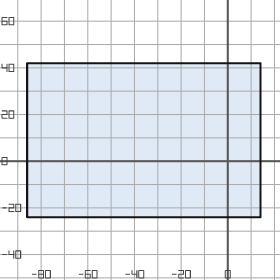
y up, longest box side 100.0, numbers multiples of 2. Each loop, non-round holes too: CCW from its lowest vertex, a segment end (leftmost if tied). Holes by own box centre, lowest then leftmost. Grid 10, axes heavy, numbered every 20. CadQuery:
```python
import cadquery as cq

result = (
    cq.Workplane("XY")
    .moveTo(-86.0, -24.0)
    .lineTo(14.0, -24.0)
    .lineTo(14.0, 42.0)
    .lineTo(-86.0, 42.0)
    .close()
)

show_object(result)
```